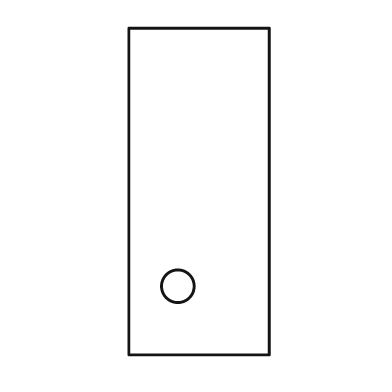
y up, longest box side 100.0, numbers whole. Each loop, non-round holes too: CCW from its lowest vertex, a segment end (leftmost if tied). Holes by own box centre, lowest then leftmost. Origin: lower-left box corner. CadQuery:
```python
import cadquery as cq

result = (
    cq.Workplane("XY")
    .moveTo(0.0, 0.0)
    .lineTo(43.0, 0.0)
    .lineTo(43.0, 100.0)
    .lineTo(0.0, 100.0)
    .close()
    .moveTo(15.0, 21.0)
    .circle(5.0)
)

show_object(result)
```